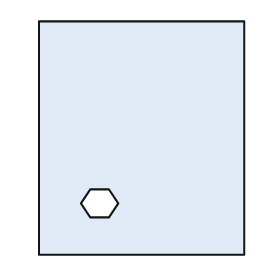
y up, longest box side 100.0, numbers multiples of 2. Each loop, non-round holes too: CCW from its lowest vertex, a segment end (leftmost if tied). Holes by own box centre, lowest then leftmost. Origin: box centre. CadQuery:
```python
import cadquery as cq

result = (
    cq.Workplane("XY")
    .moveTo(-44.0, -50.0)
    .lineTo(44.0, -50.0)
    .lineTo(44.0, 50.0)
    .lineTo(-44.0, 50.0)
    .close()
    .moveTo(-22.0, -34.0)
    .lineTo(-14.0, -34.0)
    .lineTo(-10.0, -28.0)
    .lineTo(-14.0, -22.0)
    .lineTo(-22.0, -22.0)
    .lineTo(-26.0, -28.0)
    .close()
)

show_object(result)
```